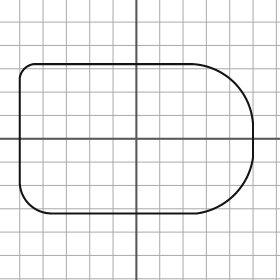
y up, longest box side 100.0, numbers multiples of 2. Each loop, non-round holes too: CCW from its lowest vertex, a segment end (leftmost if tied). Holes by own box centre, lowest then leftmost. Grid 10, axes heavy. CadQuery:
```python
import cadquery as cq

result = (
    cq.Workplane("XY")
    .moveTo(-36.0, -32.0)
    .lineTo(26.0, -32.0)
    .threePointArc((42.0, -24.0), (50.0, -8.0))
    .lineTo(50.0, 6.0)
    .threePointArc((42.0, 24.0), (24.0, 32.0))
    .lineTo(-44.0, 32.0)
    .threePointArc((-48.0, 30.0), (-50.0, 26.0))
    .lineTo(-50.0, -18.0)
    .threePointArc((-46.0, -28.0), (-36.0, -32.0))
    .close()
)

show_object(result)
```